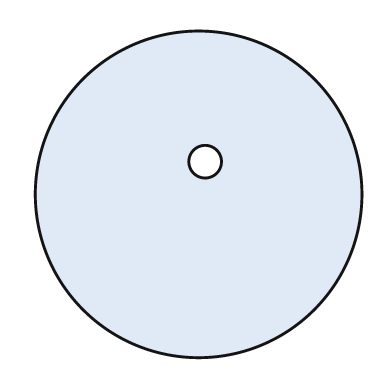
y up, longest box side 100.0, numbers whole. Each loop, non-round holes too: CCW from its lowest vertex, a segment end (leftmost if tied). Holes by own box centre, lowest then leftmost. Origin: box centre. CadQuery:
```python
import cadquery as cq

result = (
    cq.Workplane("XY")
    .moveTo(0.0, 0.0)
    .circle(50.0)
    .moveTo(2.0, 10.0)
    .circle(5.0)
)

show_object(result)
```